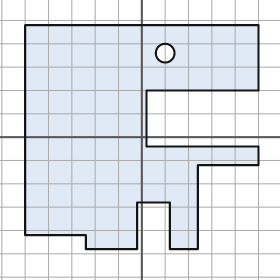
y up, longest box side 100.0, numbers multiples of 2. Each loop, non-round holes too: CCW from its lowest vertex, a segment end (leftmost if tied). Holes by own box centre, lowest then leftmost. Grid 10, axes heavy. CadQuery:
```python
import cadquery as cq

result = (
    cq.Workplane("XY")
    .moveTo(-24.0, -48.0)
    .lineTo(-2.0, -48.0)
    .lineTo(-2.0, -28.0)
    .lineTo(12.0, -28.0)
    .lineTo(12.0, -48.0)
    .lineTo(24.0, -48.0)
    .lineTo(24.0, -12.0)
    .lineTo(50.0, -12.0)
    .lineTo(50.0, -4.0)
    .lineTo(2.0, -4.0)
    .lineTo(2.0, 20.0)
    .lineTo(50.0, 20.0)
    .lineTo(50.0, 48.0)
    .lineTo(-50.0, 48.0)
    .lineTo(-50.0, -42.0)
    .lineTo(-24.0, -42.0)
    .close()
    .moveTo(10.0, 36.0)
    .circle(4.0)
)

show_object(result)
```